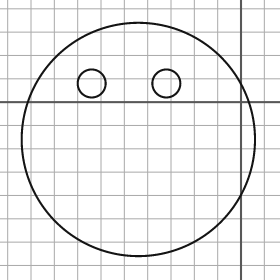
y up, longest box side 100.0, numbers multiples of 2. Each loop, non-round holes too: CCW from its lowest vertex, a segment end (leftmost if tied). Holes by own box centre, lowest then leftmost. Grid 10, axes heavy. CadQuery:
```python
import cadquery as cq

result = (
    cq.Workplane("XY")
    .moveTo(-44.0, -16.0)
    .circle(50.0)
    .moveTo(-64.0, 8.0)
    .circle(6.0)
    .moveTo(-32.0, 8.0)
    .circle(6.0)
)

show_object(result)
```